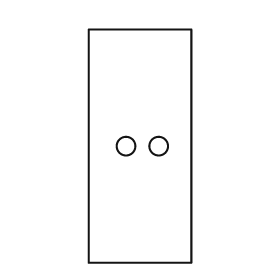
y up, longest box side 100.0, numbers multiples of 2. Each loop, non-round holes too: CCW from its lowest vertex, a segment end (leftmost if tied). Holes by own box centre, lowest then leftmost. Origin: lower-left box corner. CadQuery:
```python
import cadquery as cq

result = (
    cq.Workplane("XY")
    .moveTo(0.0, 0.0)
    .lineTo(44.0, 0.0)
    .lineTo(44.0, 100.0)
    .lineTo(0.0, 100.0)
    .close()
    .moveTo(16.0, 50.0)
    .circle(4.0)
    .moveTo(30.0, 50.0)
    .circle(4.0)
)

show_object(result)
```